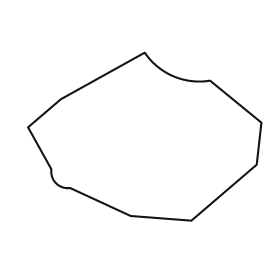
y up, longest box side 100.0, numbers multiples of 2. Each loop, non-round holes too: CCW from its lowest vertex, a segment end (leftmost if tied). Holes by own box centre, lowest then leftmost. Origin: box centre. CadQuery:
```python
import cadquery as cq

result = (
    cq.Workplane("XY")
    .moveTo(20.0, -36.0)
    .lineTo(48.0, -12.0)
    .lineTo(50.0, 6.0)
    .lineTo(28.0, 24.0)
    .threePointArc((12.0, 26.0), (0.0, 36.0))
    .lineTo(-36.0, 16.0)
    .lineTo(-50.0, 4.0)
    .lineTo(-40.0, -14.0)
    .threePointArc((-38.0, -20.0), (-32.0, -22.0))
    .lineTo(-6.0, -34.0)
    .close()
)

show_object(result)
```